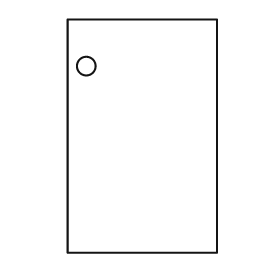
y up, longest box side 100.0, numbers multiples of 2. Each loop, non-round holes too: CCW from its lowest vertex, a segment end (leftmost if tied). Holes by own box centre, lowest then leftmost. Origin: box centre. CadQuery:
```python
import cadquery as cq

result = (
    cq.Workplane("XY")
    .moveTo(-32.0, -50.0)
    .lineTo(32.0, -50.0)
    .lineTo(32.0, 50.0)
    .lineTo(-32.0, 50.0)
    .close()
    .moveTo(-24.0, 30.0)
    .circle(4.0)
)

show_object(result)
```